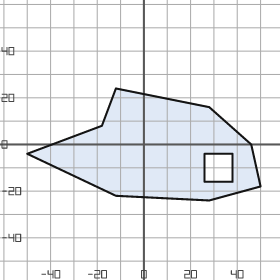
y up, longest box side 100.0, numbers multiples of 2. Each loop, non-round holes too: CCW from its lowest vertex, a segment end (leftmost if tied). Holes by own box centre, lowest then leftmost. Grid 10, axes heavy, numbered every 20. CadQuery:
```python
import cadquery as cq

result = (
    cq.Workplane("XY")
    .moveTo(28.0, -24.0)
    .lineTo(50.0, -18.0)
    .lineTo(46.0, 0.0)
    .lineTo(28.0, 16.0)
    .lineTo(-12.0, 24.0)
    .lineTo(-18.0, 8.0)
    .lineTo(-50.0, -4.0)
    .lineTo(-12.0, -22.0)
    .close()
    .moveTo(26.0, -16.0)
    .lineTo(38.0, -16.0)
    .lineTo(38.0, -4.0)
    .lineTo(26.0, -4.0)
    .close()
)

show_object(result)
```